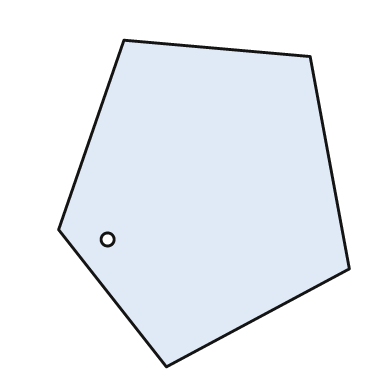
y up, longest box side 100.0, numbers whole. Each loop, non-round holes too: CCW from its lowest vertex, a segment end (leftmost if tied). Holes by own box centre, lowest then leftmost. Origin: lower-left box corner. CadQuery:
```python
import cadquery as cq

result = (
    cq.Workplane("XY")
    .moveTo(33.0, 0.0)
    .lineTo(89.0, 30.0)
    .lineTo(77.0, 95.0)
    .lineTo(20.0, 100.0)
    .lineTo(0.0, 42.0)
    .close()
    .moveTo(15.0, 39.0)
    .circle(2.0)
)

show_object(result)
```